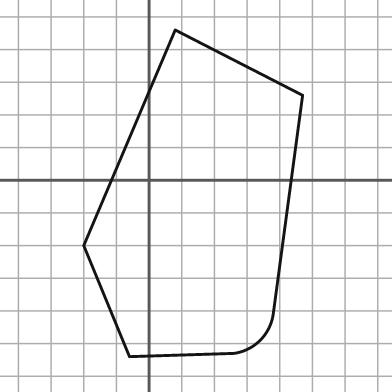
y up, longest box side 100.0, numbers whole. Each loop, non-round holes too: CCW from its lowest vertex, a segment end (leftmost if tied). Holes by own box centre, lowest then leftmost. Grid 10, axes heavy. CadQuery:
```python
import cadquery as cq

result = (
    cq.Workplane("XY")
    .moveTo(-6.0, -54.0)
    .lineTo(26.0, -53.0)
    .threePointArc((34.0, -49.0), (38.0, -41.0))
    .lineTo(47.0, 26.0)
    .lineTo(8.0, 46.0)
    .lineTo(-20.0, -20.0)
    .close()
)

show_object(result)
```